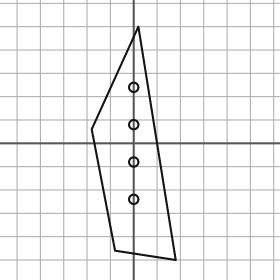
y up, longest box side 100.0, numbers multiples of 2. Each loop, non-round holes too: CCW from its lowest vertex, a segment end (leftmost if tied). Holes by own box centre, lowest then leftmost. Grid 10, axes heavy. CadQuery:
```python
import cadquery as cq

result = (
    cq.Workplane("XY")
    .moveTo(18.0, -50.0)
    .lineTo(2.0, 50.0)
    .lineTo(-18.0, 6.0)
    .lineTo(-8.0, -46.0)
    .close()
    .moveTo(0.0, -24.0)
    .circle(2.0)
    .moveTo(0.0, -8.0)
    .circle(2.0)
    .moveTo(0.0, 8.0)
    .circle(2.0)
    .moveTo(0.0, 24.0)
    .circle(2.0)
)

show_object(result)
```